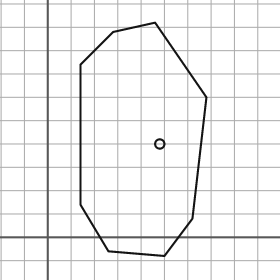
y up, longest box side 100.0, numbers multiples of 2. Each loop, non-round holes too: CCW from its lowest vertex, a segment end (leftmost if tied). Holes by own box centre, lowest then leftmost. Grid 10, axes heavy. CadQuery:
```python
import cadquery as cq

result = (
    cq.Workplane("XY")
    .moveTo(50.0, -8.0)
    .lineTo(62.0, 8.0)
    .lineTo(68.0, 60.0)
    .lineTo(46.0, 92.0)
    .lineTo(28.0, 88.0)
    .lineTo(14.0, 74.0)
    .lineTo(14.0, 14.0)
    .lineTo(26.0, -6.0)
    .close()
    .moveTo(48.0, 40.0)
    .circle(2.0)
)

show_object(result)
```